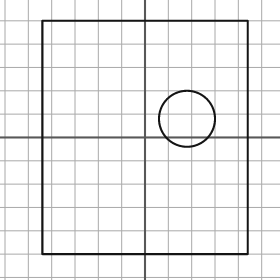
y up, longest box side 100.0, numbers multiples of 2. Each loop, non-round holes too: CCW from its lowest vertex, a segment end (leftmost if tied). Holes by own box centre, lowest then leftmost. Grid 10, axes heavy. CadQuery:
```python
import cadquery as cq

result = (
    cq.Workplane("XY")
    .moveTo(-44.0, -50.0)
    .lineTo(44.0, -50.0)
    .lineTo(44.0, 50.0)
    .lineTo(-44.0, 50.0)
    .close()
    .moveTo(18.0, 8.0)
    .circle(12.0)
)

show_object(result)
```